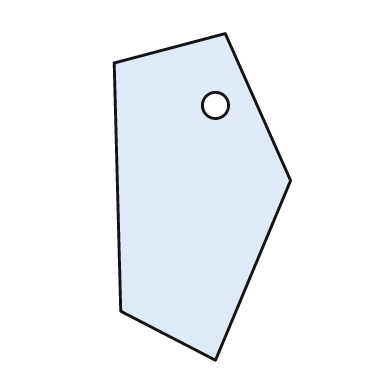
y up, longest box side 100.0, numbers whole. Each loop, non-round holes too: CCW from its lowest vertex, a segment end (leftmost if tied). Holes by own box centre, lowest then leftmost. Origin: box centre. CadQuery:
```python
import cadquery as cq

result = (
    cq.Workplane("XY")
    .moveTo(4.0, -50.0)
    .lineTo(27.0, 5.0)
    .lineTo(7.0, 50.0)
    .lineTo(-27.0, 41.0)
    .lineTo(-25.0, -35.0)
    .close()
    .moveTo(4.0, 28.0)
    .circle(4.0)
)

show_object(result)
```